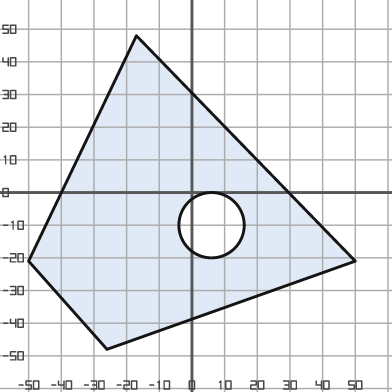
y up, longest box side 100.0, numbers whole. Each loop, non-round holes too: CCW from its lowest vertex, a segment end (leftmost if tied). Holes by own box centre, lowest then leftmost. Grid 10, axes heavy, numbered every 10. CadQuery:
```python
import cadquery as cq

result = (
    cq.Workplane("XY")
    .moveTo(-26.0, -48.0)
    .lineTo(50.0, -21.0)
    .lineTo(-17.0, 48.0)
    .lineTo(-50.0, -21.0)
    .close()
    .moveTo(6.0, -10.0)
    .circle(10.0)
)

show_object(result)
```